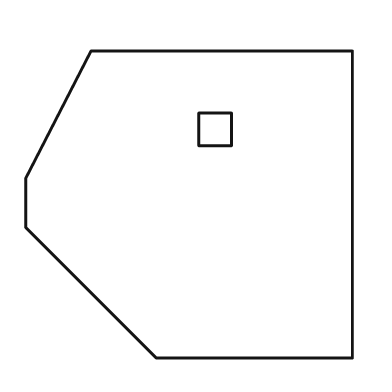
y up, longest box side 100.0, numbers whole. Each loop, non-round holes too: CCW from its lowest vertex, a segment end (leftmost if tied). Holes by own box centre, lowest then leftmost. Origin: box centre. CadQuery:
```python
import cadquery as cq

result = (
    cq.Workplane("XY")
    .moveTo(-10.0, -47.0)
    .lineTo(50.0, -47.0)
    .lineTo(50.0, 47.0)
    .lineTo(-30.0, 47.0)
    .lineTo(-50.0, 8.0)
    .lineTo(-50.0, -7.0)
    .close()
    .moveTo(3.0, 18.0)
    .lineTo(13.0, 18.0)
    .lineTo(13.0, 28.0)
    .lineTo(3.0, 28.0)
    .close()
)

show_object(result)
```